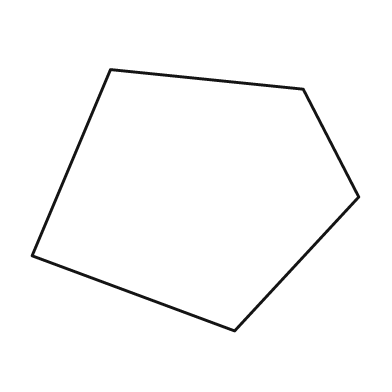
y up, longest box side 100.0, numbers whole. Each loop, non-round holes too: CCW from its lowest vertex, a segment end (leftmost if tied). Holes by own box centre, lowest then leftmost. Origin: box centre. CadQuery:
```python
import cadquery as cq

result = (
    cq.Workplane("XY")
    .moveTo(12.0, -40.0)
    .lineTo(50.0, 1.0)
    .lineTo(33.0, 34.0)
    .lineTo(-26.0, 40.0)
    .lineTo(-50.0, -17.0)
    .close()
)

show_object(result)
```